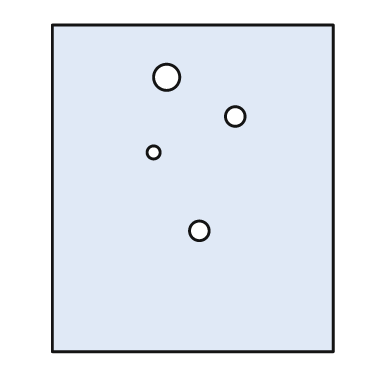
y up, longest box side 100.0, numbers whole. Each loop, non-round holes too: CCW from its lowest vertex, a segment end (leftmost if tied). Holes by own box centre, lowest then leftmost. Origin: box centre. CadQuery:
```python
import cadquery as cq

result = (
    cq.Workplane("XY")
    .moveTo(-43.0, -50.0)
    .lineTo(43.0, -50.0)
    .lineTo(43.0, 50.0)
    .lineTo(-43.0, 50.0)
    .close()
    .moveTo(2.0, -13.0)
    .circle(3.0)
    .moveTo(-12.0, 11.0)
    .circle(2.0)
    .moveTo(13.0, 22.0)
    .circle(3.0)
    .moveTo(-8.0, 34.0)
    .circle(4.0)
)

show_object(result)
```